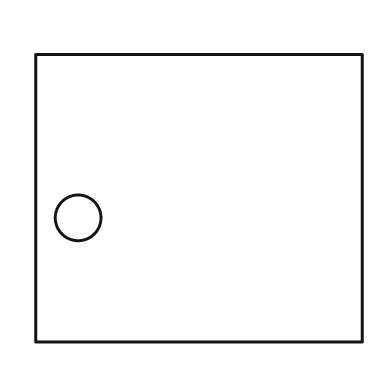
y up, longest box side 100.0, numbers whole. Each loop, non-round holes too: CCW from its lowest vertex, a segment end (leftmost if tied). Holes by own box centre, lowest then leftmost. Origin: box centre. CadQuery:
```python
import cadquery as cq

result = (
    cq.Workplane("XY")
    .moveTo(-50.0, -44.0)
    .lineTo(50.0, -44.0)
    .lineTo(50.0, 44.0)
    .lineTo(-50.0, 44.0)
    .close()
    .moveTo(-37.0, -6.0)
    .circle(7.0)
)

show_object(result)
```